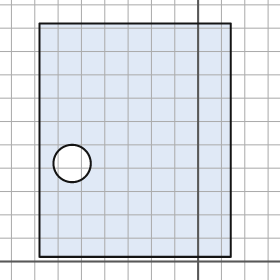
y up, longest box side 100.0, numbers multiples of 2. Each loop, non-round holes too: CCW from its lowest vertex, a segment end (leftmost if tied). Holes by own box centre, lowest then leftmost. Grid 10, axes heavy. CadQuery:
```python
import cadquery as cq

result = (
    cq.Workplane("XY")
    .moveTo(-68.0, 2.0)
    .lineTo(14.0, 2.0)
    .lineTo(14.0, 102.0)
    .lineTo(-68.0, 102.0)
    .close()
    .moveTo(-54.0, 42.0)
    .circle(8.0)
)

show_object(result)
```